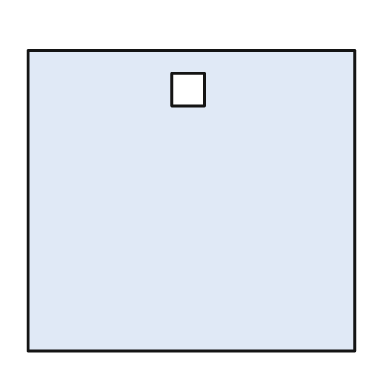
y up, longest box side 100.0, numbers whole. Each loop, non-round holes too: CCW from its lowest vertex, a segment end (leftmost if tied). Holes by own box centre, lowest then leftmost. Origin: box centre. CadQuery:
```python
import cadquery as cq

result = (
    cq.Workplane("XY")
    .moveTo(-50.0, -46.0)
    .lineTo(50.0, -46.0)
    .lineTo(50.0, 46.0)
    .lineTo(-50.0, 46.0)
    .close()
    .moveTo(-6.0, 29.0)
    .lineTo(4.0, 29.0)
    .lineTo(4.0, 39.0)
    .lineTo(-6.0, 39.0)
    .close()
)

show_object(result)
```